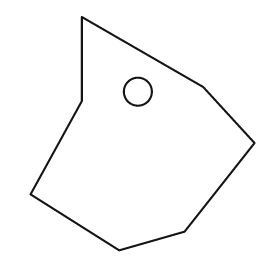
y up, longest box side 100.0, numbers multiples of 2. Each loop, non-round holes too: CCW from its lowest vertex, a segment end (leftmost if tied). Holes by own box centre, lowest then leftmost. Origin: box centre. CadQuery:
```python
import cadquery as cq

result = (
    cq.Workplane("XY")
    .moveTo(-10.0, -50.0)
    .lineTo(18.0, -42.0)
    .lineTo(48.0, -4.0)
    .lineTo(26.0, 20.0)
    .lineTo(-26.0, 50.0)
    .lineTo(-26.0, 14.0)
    .lineTo(-48.0, -26.0)
    .close()
    .moveTo(-2.0, 18.0)
    .circle(6.0)
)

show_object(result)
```